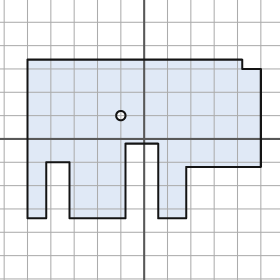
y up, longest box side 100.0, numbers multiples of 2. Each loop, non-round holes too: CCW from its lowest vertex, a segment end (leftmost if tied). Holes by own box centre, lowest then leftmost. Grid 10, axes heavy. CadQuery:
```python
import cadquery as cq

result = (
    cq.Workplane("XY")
    .moveTo(-50.0, -34.0)
    .lineTo(-42.0, -34.0)
    .lineTo(-42.0, -10.0)
    .lineTo(-32.0, -10.0)
    .lineTo(-32.0, -34.0)
    .lineTo(-8.0, -34.0)
    .lineTo(-8.0, -2.0)
    .lineTo(6.0, -2.0)
    .lineTo(6.0, -34.0)
    .lineTo(18.0, -34.0)
    .lineTo(18.0, -12.0)
    .lineTo(50.0, -12.0)
    .lineTo(50.0, 30.0)
    .lineTo(42.0, 30.0)
    .lineTo(42.0, 34.0)
    .lineTo(-50.0, 34.0)
    .close()
    .moveTo(-10.0, 10.0)
    .circle(2.0)
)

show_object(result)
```